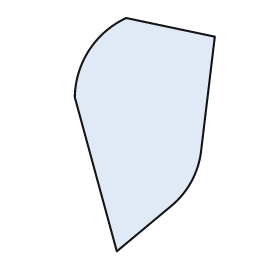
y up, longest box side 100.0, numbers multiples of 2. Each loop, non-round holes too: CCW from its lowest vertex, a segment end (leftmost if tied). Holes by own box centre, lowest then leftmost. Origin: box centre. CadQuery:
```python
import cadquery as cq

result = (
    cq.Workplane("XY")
    .moveTo(-12.0, -50.0)
    .lineTo(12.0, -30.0)
    .threePointArc((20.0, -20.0), (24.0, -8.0))
    .lineTo(30.0, 42.0)
    .lineTo(-8.0, 50.0)
    .threePointArc((-24.0, 36.0), (-30.0, 16.0))
    .close()
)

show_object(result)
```